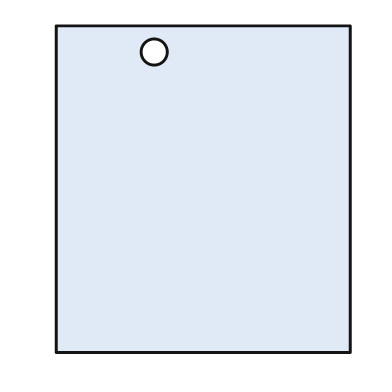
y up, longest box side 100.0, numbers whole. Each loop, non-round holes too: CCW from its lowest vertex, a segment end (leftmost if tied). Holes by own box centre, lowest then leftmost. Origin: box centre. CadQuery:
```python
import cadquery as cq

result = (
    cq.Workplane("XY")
    .moveTo(-45.0, -50.0)
    .lineTo(45.0, -50.0)
    .lineTo(45.0, 50.0)
    .lineTo(-45.0, 50.0)
    .close()
    .moveTo(-15.0, 42.0)
    .circle(4.0)
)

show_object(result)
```